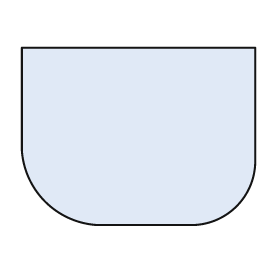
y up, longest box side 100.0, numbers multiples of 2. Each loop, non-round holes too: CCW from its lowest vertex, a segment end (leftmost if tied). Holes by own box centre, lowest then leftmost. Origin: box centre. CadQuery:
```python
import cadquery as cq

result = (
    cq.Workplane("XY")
    .moveTo(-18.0, -38.0)
    .lineTo(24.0, -38.0)
    .threePointArc((42.0, -30.0), (50.0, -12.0))
    .lineTo(50.0, 38.0)
    .lineTo(-50.0, 38.0)
    .lineTo(-50.0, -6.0)
    .threePointArc((-40.0, -28.0), (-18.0, -38.0))
    .close()
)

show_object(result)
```